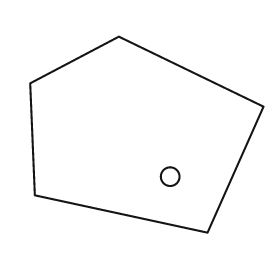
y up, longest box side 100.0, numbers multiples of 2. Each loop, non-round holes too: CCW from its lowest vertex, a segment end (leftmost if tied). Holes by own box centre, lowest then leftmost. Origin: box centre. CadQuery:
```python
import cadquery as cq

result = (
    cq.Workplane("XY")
    .moveTo(26.0, -42.0)
    .lineTo(50.0, 12.0)
    .lineTo(-12.0, 42.0)
    .lineTo(-50.0, 22.0)
    .lineTo(-48.0, -26.0)
    .close()
    .moveTo(10.0, -18.0)
    .circle(4.0)
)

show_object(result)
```